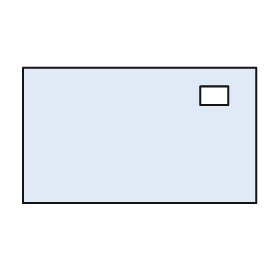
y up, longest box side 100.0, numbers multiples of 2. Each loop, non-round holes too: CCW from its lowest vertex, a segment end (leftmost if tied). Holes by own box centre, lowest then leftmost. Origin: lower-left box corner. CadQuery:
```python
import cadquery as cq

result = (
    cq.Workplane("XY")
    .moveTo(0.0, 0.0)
    .lineTo(100.0, 0.0)
    .lineTo(100.0, 58.0)
    .lineTo(0.0, 58.0)
    .close()
    .moveTo(76.0, 42.0)
    .lineTo(88.0, 42.0)
    .lineTo(88.0, 50.0)
    .lineTo(76.0, 50.0)
    .close()
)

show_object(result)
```